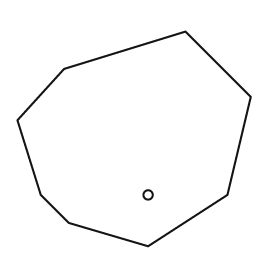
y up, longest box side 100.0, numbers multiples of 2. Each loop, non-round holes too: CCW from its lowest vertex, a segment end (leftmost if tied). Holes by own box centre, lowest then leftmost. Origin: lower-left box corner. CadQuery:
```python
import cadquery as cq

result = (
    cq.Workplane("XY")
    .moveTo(56.0, 0.0)
    .lineTo(90.0, 22.0)
    .lineTo(100.0, 64.0)
    .lineTo(72.0, 92.0)
    .lineTo(20.0, 76.0)
    .lineTo(0.0, 54.0)
    .lineTo(10.0, 22.0)
    .lineTo(22.0, 10.0)
    .close()
    .moveTo(56.0, 22.0)
    .circle(2.0)
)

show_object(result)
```